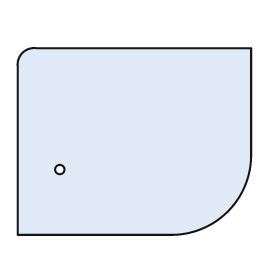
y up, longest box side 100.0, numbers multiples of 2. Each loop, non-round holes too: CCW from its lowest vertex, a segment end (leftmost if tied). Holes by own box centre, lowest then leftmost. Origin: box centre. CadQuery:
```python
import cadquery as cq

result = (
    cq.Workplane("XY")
    .moveTo(-50.0, -40.0)
    .lineTo(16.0, -40.0)
    .threePointArc((40.0, -30.0), (50.0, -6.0))
    .lineTo(50.0, 40.0)
    .lineTo(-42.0, 40.0)
    .threePointArc((-48.0, 38.0), (-50.0, 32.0))
    .close()
    .moveTo(-32.0, -12.0)
    .circle(2.0)
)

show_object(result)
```